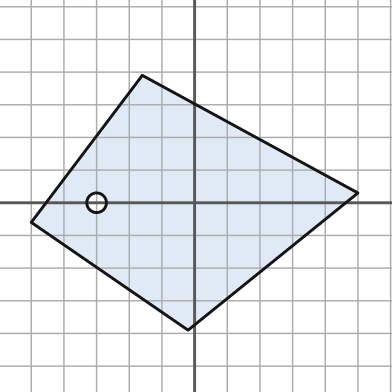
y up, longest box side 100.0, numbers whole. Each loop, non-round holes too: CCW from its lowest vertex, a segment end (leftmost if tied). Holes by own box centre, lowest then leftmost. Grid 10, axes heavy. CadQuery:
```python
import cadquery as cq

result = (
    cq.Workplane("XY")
    .moveTo(-2.0, -39.0)
    .lineTo(50.0, 3.0)
    .lineTo(-16.0, 39.0)
    .lineTo(-50.0, -6.0)
    .close()
    .moveTo(-30.0, 0.0)
    .circle(3.0)
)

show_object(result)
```